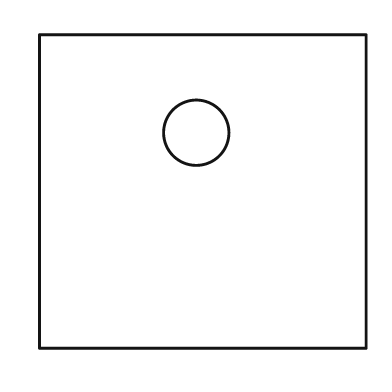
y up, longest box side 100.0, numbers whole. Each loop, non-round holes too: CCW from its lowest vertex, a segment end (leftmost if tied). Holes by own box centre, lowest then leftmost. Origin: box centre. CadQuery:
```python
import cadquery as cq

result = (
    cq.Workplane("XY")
    .moveTo(-50.0, -48.0)
    .lineTo(50.0, -48.0)
    .lineTo(50.0, 48.0)
    .lineTo(-50.0, 48.0)
    .close()
    .moveTo(-2.0, 18.0)
    .circle(10.0)
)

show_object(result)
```